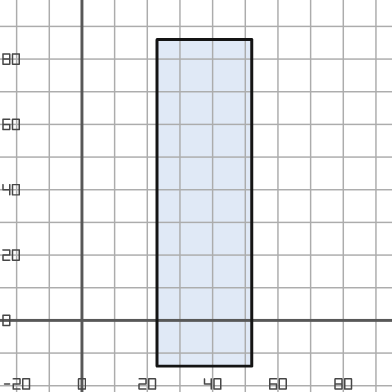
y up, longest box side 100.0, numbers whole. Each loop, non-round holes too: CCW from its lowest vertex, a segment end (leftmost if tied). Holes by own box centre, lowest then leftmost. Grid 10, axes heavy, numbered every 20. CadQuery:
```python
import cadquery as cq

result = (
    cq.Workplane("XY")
    .moveTo(23.0, -14.0)
    .lineTo(52.0, -14.0)
    .lineTo(52.0, 86.0)
    .lineTo(23.0, 86.0)
    .close()
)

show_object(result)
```